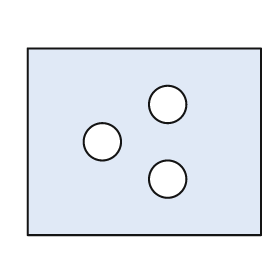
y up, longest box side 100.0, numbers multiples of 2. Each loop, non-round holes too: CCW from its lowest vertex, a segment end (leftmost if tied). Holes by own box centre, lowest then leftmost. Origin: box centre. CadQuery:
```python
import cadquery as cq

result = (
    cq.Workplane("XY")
    .moveTo(-50.0, -40.0)
    .lineTo(50.0, -40.0)
    .lineTo(50.0, 40.0)
    .lineTo(-50.0, 40.0)
    .close()
    .moveTo(10.0, -16.0)
    .circle(8.0)
    .moveTo(-18.0, 0.0)
    .circle(8.0)
    .moveTo(10.0, 16.0)
    .circle(8.0)
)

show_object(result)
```